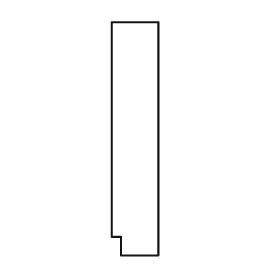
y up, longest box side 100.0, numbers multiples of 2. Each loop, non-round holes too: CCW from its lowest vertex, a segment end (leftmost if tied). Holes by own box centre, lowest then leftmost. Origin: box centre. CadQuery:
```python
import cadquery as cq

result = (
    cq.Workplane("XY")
    .moveTo(-6.0, -50.0)
    .lineTo(10.0, -50.0)
    .lineTo(10.0, 50.0)
    .lineTo(-10.0, 50.0)
    .lineTo(-10.0, -42.0)
    .lineTo(-6.0, -42.0)
    .close()
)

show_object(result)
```